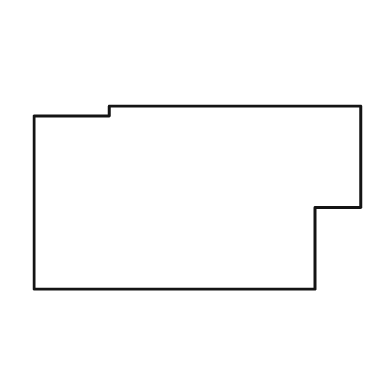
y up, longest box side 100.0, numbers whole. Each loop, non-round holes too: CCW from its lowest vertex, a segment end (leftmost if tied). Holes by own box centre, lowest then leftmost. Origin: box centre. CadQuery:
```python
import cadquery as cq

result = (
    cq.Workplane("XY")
    .moveTo(-50.0, -28.0)
    .lineTo(36.0, -28.0)
    .lineTo(36.0, -3.0)
    .lineTo(50.0, -3.0)
    .lineTo(50.0, 28.0)
    .lineTo(-27.0, 28.0)
    .lineTo(-27.0, 25.0)
    .lineTo(-50.0, 25.0)
    .close()
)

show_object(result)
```